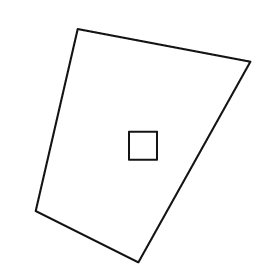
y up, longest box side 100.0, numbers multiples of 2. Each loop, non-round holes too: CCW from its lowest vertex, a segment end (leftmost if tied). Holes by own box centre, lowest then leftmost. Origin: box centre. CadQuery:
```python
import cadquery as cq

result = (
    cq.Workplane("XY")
    .moveTo(-2.0, -50.0)
    .lineTo(46.0, 36.0)
    .lineTo(-28.0, 50.0)
    .lineTo(-46.0, -28.0)
    .close()
    .moveTo(-6.0, -6.0)
    .lineTo(6.0, -6.0)
    .lineTo(6.0, 6.0)
    .lineTo(-6.0, 6.0)
    .close()
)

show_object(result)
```